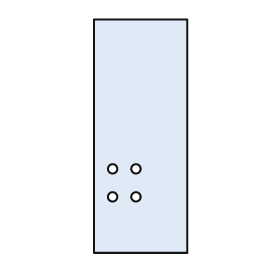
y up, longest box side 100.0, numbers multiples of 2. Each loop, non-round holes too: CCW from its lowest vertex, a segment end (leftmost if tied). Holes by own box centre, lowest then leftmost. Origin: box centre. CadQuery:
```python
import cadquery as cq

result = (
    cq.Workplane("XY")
    .moveTo(-20.0, -50.0)
    .lineTo(20.0, -50.0)
    .lineTo(20.0, 50.0)
    .lineTo(-20.0, 50.0)
    .close()
    .moveTo(-12.0, -26.0)
    .circle(2.0)
    .moveTo(-2.0, -26.0)
    .circle(2.0)
    .moveTo(-12.0, -14.0)
    .circle(2.0)
    .moveTo(-2.0, -14.0)
    .circle(2.0)
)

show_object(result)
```